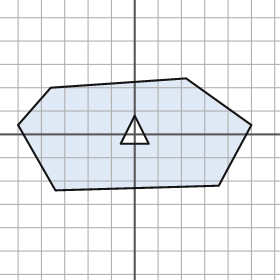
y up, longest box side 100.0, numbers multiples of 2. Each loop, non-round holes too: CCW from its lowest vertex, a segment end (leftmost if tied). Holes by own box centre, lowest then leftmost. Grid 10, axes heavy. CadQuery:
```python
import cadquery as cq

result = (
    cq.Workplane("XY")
    .moveTo(-34.0, -24.0)
    .lineTo(36.0, -22.0)
    .lineTo(50.0, 4.0)
    .lineTo(22.0, 24.0)
    .lineTo(-36.0, 20.0)
    .lineTo(-50.0, 4.0)
    .close()
    .moveTo(-6.0, -4.0)
    .lineTo(6.0, -4.0)
    .lineTo(0.0, 8.0)
    .close()
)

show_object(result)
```